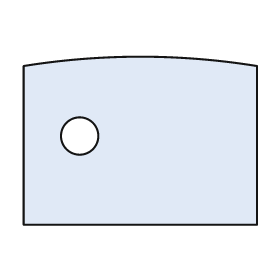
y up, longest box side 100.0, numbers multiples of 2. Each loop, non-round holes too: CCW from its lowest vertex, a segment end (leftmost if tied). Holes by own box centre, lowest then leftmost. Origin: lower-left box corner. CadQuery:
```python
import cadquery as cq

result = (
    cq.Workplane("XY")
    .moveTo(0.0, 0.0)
    .lineTo(100.0, 0.0)
    .lineTo(100.0, 68.0)
    .threePointArc((50.0, 72.0), (0.0, 68.0))
    .close()
    .moveTo(24.0, 38.0)
    .circle(8.0)
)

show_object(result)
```